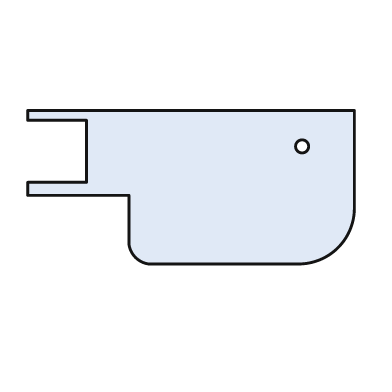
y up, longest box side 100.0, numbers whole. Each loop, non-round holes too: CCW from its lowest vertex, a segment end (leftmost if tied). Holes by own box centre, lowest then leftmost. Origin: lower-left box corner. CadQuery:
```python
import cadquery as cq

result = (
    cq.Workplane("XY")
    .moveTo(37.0, 0.0)
    .lineTo(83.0, 0.0)
    .threePointArc((95.0, 5.0), (100.0, 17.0))
    .lineTo(100.0, 47.0)
    .lineTo(0.0, 47.0)
    .lineTo(0.0, 44.0)
    .lineTo(18.0, 44.0)
    .lineTo(18.0, 25.0)
    .lineTo(0.0, 25.0)
    .lineTo(0.0, 21.0)
    .lineTo(31.0, 21.0)
    .lineTo(31.0, 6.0)
    .threePointArc((33.0, 2.0), (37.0, 0.0))
    .close()
    .moveTo(84.0, 36.0)
    .circle(2.0)
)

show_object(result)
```